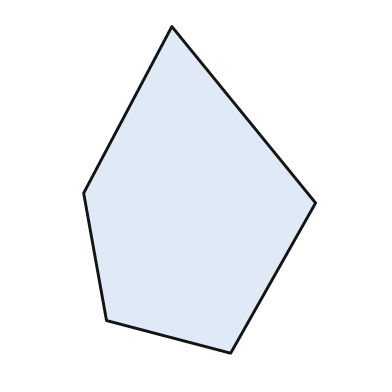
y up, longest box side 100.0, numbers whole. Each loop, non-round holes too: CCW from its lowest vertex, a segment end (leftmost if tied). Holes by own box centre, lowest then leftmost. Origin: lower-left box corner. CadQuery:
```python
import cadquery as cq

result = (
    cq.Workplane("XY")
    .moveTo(45.0, 0.0)
    .lineTo(71.0, 46.0)
    .lineTo(27.0, 100.0)
    .lineTo(0.0, 49.0)
    .lineTo(7.0, 10.0)
    .close()
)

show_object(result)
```